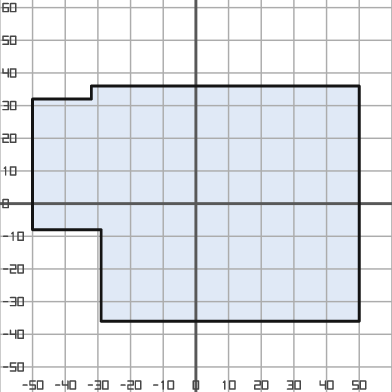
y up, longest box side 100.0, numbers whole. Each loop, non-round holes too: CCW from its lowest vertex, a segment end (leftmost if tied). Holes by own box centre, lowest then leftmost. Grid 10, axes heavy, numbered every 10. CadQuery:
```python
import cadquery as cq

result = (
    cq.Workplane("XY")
    .moveTo(-29.0, -36.0)
    .lineTo(50.0, -36.0)
    .lineTo(50.0, 36.0)
    .lineTo(-32.0, 36.0)
    .lineTo(-32.0, 32.0)
    .lineTo(-50.0, 32.0)
    .lineTo(-50.0, -8.0)
    .lineTo(-29.0, -8.0)
    .close()
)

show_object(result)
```